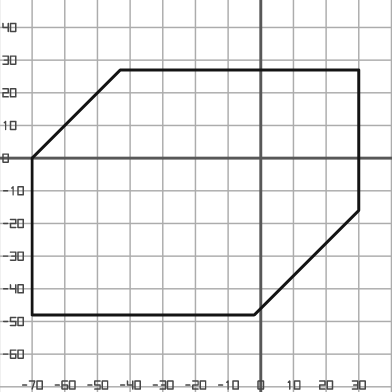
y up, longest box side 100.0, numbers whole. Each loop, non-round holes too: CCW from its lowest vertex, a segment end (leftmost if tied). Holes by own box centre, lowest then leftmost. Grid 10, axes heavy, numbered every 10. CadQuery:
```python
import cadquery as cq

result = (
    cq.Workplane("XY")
    .moveTo(-70.0, -48.0)
    .lineTo(-2.0, -48.0)
    .lineTo(30.0, -16.0)
    .lineTo(30.0, 27.0)
    .lineTo(-43.0, 27.0)
    .lineTo(-70.0, 0.0)
    .close()
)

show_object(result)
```